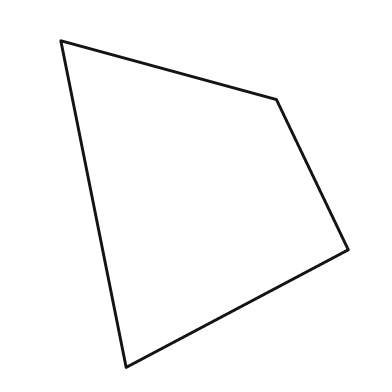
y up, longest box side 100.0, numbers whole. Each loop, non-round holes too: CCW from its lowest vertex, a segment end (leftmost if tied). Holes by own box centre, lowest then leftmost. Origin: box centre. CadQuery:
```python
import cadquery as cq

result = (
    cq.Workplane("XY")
    .moveTo(-24.0, -50.0)
    .lineTo(44.0, -14.0)
    .lineTo(22.0, 32.0)
    .lineTo(-44.0, 50.0)
    .close()
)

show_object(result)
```